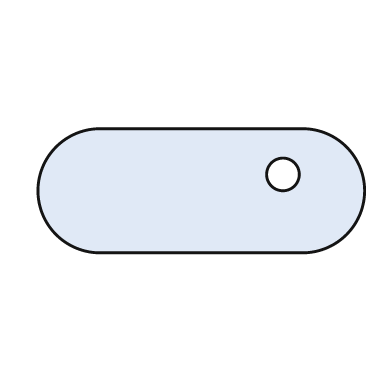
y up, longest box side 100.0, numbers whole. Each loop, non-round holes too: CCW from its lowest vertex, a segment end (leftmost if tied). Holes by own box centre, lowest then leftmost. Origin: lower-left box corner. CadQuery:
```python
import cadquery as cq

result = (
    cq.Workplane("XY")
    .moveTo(19.0, 0.0)
    .lineTo(81.0, 0.0)
    .threePointArc((100.0, 19.0), (81.0, 38.0))
    .lineTo(19.0, 38.0)
    .threePointArc((0.0, 19.0), (19.0, 0.0))
    .close()
    .moveTo(75.0, 24.0)
    .circle(5.0)
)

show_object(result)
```